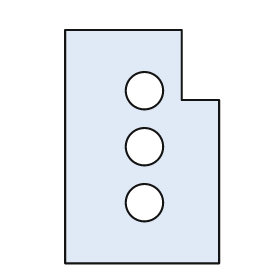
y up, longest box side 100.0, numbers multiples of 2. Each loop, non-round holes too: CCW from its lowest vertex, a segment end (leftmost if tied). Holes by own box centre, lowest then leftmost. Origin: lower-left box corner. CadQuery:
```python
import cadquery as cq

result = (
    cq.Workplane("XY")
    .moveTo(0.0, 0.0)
    .lineTo(66.0, 0.0)
    .lineTo(66.0, 70.0)
    .lineTo(50.0, 70.0)
    .lineTo(50.0, 100.0)
    .lineTo(0.0, 100.0)
    .close()
    .moveTo(34.0, 26.0)
    .circle(8.0)
    .moveTo(34.0, 50.0)
    .circle(8.0)
    .moveTo(34.0, 74.0)
    .circle(8.0)
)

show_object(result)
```